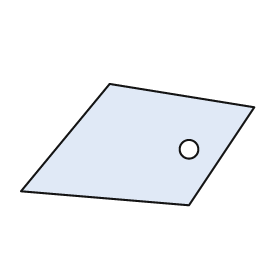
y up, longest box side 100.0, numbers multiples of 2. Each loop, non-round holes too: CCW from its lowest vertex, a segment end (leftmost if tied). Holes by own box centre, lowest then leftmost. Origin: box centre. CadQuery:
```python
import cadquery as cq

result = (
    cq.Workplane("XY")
    .moveTo(22.0, -26.0)
    .lineTo(50.0, 16.0)
    .lineTo(-12.0, 26.0)
    .lineTo(-50.0, -20.0)
    .close()
    .moveTo(22.0, -2.0)
    .circle(4.0)
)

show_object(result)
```